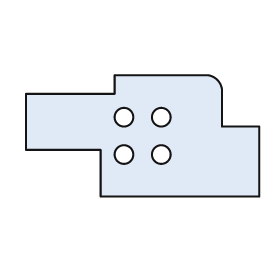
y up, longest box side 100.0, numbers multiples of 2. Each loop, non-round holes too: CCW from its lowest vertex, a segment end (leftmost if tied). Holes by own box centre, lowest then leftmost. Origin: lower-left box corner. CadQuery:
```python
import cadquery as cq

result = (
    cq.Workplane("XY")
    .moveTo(32.0, 0.0)
    .lineTo(100.0, 0.0)
    .lineTo(100.0, 30.0)
    .lineTo(84.0, 30.0)
    .lineTo(84.0, 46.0)
    .threePointArc((82.0, 50.0), (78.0, 52.0))
    .lineTo(38.0, 52.0)
    .lineTo(38.0, 44.0)
    .lineTo(0.0, 44.0)
    .lineTo(0.0, 20.0)
    .lineTo(32.0, 20.0)
    .close()
    .moveTo(42.0, 18.0)
    .circle(4.0)
    .moveTo(58.0, 18.0)
    .circle(4.0)
    .moveTo(42.0, 34.0)
    .circle(4.0)
    .moveTo(58.0, 34.0)
    .circle(4.0)
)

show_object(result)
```